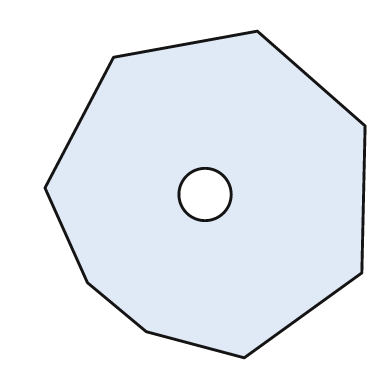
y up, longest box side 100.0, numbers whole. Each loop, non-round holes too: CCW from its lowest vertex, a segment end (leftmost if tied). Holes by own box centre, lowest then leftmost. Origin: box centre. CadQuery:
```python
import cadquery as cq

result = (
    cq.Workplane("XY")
    .moveTo(12.0, -50.0)
    .lineTo(48.0, -24.0)
    .lineTo(49.0, 21.0)
    .lineTo(16.0, 50.0)
    .lineTo(-28.0, 42.0)
    .lineTo(-49.0, 2.0)
    .lineTo(-36.0, -27.0)
    .lineTo(-18.0, -42.0)
    .close()
    .moveTo(0.0, 0.0)
    .circle(8.0)
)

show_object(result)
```